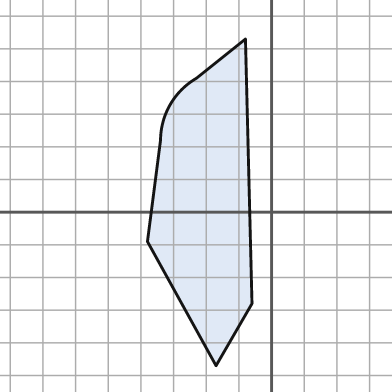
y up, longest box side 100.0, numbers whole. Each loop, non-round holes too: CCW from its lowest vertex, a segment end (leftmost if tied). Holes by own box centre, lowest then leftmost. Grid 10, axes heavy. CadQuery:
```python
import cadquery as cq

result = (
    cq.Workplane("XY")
    .moveTo(-17.0, -47.0)
    .lineTo(-6.0, -28.0)
    .lineTo(-8.0, 53.0)
    .lineTo(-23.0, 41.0)
    .threePointArc((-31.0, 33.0), (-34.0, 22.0))
    .lineTo(-38.0, -9.0)
    .close()
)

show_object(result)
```